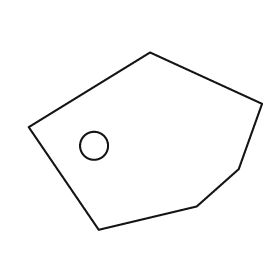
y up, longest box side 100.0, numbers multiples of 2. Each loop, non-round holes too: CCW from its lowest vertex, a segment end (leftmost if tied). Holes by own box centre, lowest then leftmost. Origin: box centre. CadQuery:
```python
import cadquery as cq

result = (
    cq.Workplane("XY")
    .moveTo(-20.0, -38.0)
    .lineTo(22.0, -28.0)
    .lineTo(40.0, -12.0)
    .lineTo(50.0, 16.0)
    .lineTo(2.0, 38.0)
    .lineTo(-50.0, 6.0)
    .close()
    .moveTo(-22.0, -2.0)
    .circle(6.0)
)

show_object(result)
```